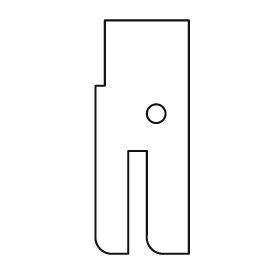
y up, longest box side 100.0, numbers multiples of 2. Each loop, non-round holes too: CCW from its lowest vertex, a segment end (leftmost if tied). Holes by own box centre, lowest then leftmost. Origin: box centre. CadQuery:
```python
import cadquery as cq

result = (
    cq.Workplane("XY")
    .moveTo(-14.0, -50.0)
    .lineTo(-6.0, -50.0)
    .lineTo(-6.0, -6.0)
    .lineTo(2.0, -6.0)
    .lineTo(2.0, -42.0)
    .threePointArc((4.0, -48.0), (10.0, -50.0))
    .lineTo(20.0, -50.0)
    .lineTo(20.0, 50.0)
    .lineTo(-16.0, 50.0)
    .lineTo(-16.0, 22.0)
    .lineTo(-20.0, 22.0)
    .lineTo(-20.0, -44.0)
    .threePointArc((-18.0, -48.0), (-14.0, -50.0))
    .close()
    .moveTo(6.0, 10.0)
    .circle(4.0)
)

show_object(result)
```